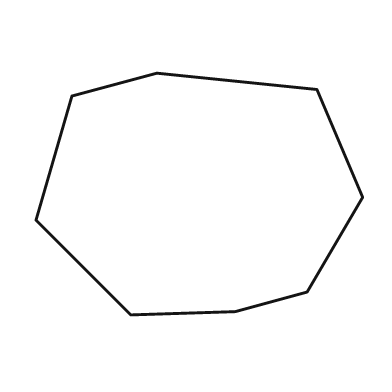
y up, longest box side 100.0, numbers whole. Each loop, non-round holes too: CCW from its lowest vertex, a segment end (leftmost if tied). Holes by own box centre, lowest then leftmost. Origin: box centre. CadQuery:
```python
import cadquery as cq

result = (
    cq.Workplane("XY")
    .moveTo(-21.0, -37.0)
    .lineTo(11.0, -36.0)
    .lineTo(33.0, -30.0)
    .lineTo(50.0, -1.0)
    .lineTo(36.0, 32.0)
    .lineTo(-13.0, 37.0)
    .lineTo(-39.0, 30.0)
    .lineTo(-50.0, -8.0)
    .close()
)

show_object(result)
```